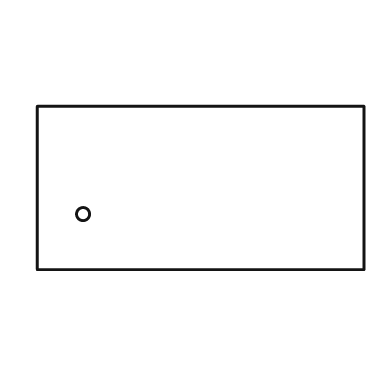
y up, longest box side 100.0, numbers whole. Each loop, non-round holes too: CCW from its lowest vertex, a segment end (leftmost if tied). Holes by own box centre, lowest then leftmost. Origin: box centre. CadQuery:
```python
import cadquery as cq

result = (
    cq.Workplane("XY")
    .moveTo(-50.0, -25.0)
    .lineTo(50.0, -25.0)
    .lineTo(50.0, 25.0)
    .lineTo(-50.0, 25.0)
    .close()
    .moveTo(-36.0, -8.0)
    .circle(2.0)
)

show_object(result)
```